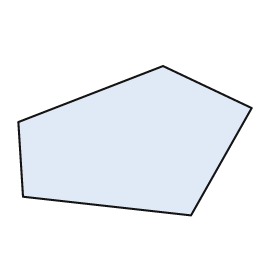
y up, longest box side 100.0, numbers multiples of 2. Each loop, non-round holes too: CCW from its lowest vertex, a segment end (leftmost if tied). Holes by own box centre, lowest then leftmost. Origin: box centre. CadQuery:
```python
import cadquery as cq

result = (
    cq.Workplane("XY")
    .moveTo(24.0, -32.0)
    .lineTo(50.0, 14.0)
    .lineTo(12.0, 32.0)
    .lineTo(-50.0, 8.0)
    .lineTo(-48.0, -24.0)
    .close()
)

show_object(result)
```